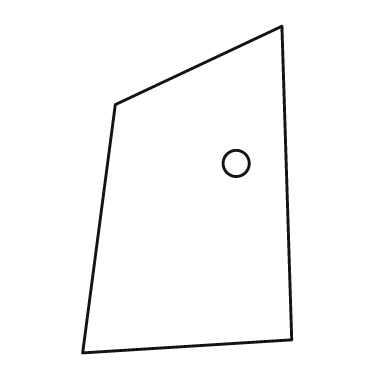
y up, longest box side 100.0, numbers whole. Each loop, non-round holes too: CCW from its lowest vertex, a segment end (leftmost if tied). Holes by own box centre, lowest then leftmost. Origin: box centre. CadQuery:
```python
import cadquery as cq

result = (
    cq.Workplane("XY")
    .moveTo(-32.0, -50.0)
    .lineTo(32.0, -46.0)
    .lineTo(29.0, 50.0)
    .lineTo(-22.0, 26.0)
    .close()
    .moveTo(15.0, 8.0)
    .circle(4.0)
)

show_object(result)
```